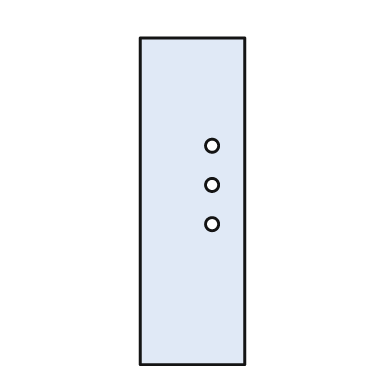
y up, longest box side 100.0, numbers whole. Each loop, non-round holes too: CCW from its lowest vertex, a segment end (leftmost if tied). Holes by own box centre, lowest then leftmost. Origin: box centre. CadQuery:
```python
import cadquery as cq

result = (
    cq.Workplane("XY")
    .moveTo(-16.0, -50.0)
    .lineTo(16.0, -50.0)
    .lineTo(16.0, 50.0)
    .lineTo(-16.0, 50.0)
    .close()
    .moveTo(6.0, -7.0)
    .circle(2.0)
    .moveTo(6.0, 5.0)
    .circle(2.0)
    .moveTo(6.0, 17.0)
    .circle(2.0)
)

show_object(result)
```